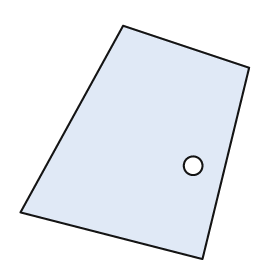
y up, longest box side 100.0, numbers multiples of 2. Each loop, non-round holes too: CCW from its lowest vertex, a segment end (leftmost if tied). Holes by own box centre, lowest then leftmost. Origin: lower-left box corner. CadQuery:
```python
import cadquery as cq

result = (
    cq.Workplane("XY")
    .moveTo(78.0, 0.0)
    .lineTo(98.0, 82.0)
    .lineTo(44.0, 100.0)
    .lineTo(0.0, 20.0)
    .close()
    .moveTo(74.0, 40.0)
    .circle(4.0)
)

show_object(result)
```